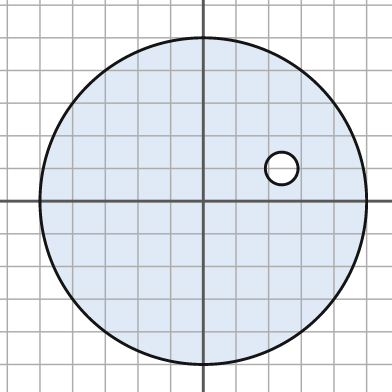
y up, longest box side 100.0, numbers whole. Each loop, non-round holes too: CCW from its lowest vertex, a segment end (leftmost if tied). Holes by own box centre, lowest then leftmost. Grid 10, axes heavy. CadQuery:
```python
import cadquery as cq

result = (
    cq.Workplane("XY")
    .moveTo(0.0, 0.0)
    .circle(50.0)
    .moveTo(24.0, 10.0)
    .circle(5.0)
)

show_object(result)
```